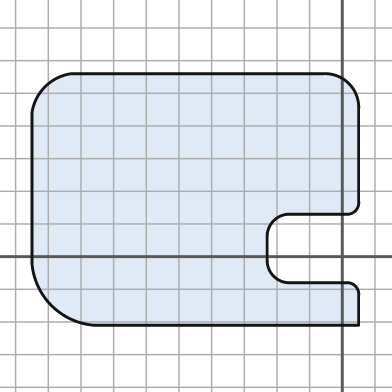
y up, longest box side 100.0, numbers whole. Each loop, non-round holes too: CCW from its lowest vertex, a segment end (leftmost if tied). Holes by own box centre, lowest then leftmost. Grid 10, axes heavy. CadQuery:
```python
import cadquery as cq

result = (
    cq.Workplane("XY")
    .moveTo(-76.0, -21.0)
    .lineTo(5.0, -21.0)
    .lineTo(5.0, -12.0)
    .threePointArc((4.0, -9.0), (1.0, -8.0))
    .lineTo(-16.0, -8.0)
    .threePointArc((-21.0, -6.0), (-23.0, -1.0))
    .lineTo(-23.0, 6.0)
    .threePointArc((-21.0, 11.0), (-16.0, 13.0))
    .lineTo(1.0, 13.0)
    .threePointArc((4.0, 14.0), (5.0, 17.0))
    .lineTo(5.0, 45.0)
    .threePointArc((2.0, 53.0), (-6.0, 56.0))
    .lineTo(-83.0, 56.0)
    .threePointArc((-91.0, 52.0), (-95.0, 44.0))
    .lineTo(-95.0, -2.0)
    .threePointArc((-89.0, -15.0), (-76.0, -21.0))
    .close()
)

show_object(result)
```